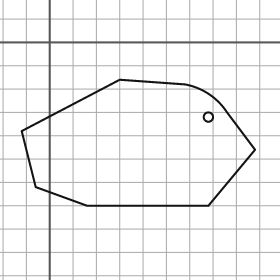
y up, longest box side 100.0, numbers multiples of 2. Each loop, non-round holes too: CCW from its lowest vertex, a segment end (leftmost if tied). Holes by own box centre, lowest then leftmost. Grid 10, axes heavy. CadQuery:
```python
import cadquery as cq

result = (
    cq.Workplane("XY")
    .moveTo(16.0, -70.0)
    .lineTo(68.0, -70.0)
    .lineTo(88.0, -46.0)
    .lineTo(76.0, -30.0)
    .threePointArc((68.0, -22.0), (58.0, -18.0))
    .lineTo(30.0, -16.0)
    .lineTo(-12.0, -38.0)
    .lineTo(-6.0, -62.0)
    .close()
    .moveTo(68.0, -32.0)
    .circle(2.0)
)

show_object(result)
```